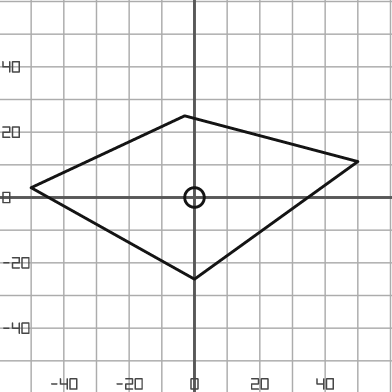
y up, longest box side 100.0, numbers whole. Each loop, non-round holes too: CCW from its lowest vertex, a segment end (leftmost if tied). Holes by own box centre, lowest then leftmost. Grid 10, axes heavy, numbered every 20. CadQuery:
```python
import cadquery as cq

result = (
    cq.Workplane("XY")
    .moveTo(0.0, -25.0)
    .lineTo(50.0, 11.0)
    .lineTo(-3.0, 25.0)
    .lineTo(-50.0, 3.0)
    .close()
    .moveTo(0.0, 0.0)
    .circle(3.0)
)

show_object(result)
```